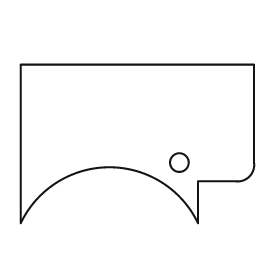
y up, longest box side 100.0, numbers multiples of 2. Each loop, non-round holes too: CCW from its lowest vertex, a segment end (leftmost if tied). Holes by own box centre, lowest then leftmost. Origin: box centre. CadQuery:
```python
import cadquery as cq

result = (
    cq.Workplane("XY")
    .moveTo(-50.0, -34.0)
    .threePointArc((-12.0, -10.0), (26.0, -34.0))
    .lineTo(26.0, -16.0)
    .lineTo(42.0, -16.0)
    .threePointArc((48.0, -14.0), (50.0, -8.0))
    .lineTo(50.0, 34.0)
    .lineTo(-50.0, 34.0)
    .close()
    .moveTo(18.0, -8.0)
    .circle(4.0)
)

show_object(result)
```